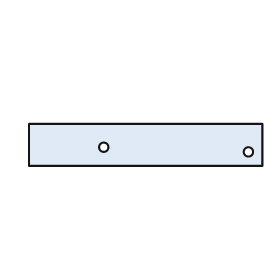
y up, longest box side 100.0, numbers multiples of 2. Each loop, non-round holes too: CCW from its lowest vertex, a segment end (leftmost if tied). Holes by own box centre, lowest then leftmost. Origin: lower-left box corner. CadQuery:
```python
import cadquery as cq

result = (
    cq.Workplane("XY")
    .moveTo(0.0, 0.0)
    .lineTo(100.0, 0.0)
    .lineTo(100.0, 18.0)
    .lineTo(0.0, 18.0)
    .close()
    .moveTo(94.0, 6.0)
    .circle(2.0)
    .moveTo(32.0, 8.0)
    .circle(2.0)
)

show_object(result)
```